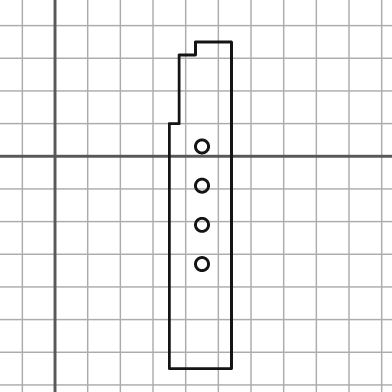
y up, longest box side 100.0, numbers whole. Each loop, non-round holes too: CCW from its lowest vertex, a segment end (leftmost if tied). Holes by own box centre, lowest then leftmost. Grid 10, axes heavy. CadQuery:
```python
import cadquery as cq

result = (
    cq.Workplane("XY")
    .moveTo(35.0, -65.0)
    .lineTo(54.0, -65.0)
    .lineTo(54.0, 35.0)
    .lineTo(43.0, 35.0)
    .lineTo(43.0, 31.0)
    .lineTo(38.0, 31.0)
    .lineTo(38.0, 10.0)
    .lineTo(35.0, 10.0)
    .close()
    .moveTo(45.0, -33.0)
    .circle(2.0)
    .moveTo(45.0, -21.0)
    .circle(2.0)
    .moveTo(45.0, -9.0)
    .circle(2.0)
    .moveTo(45.0, 3.0)
    .circle(2.0)
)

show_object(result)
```